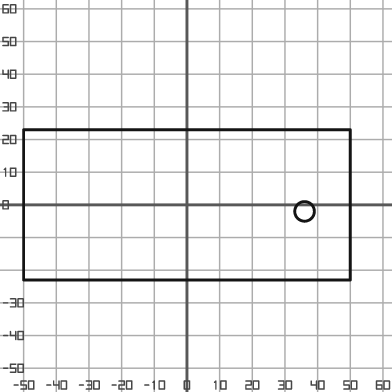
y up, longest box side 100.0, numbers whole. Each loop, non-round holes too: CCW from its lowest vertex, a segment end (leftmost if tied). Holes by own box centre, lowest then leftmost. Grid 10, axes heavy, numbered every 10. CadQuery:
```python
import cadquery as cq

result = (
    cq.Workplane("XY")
    .moveTo(-50.0, -23.0)
    .lineTo(50.0, -23.0)
    .lineTo(50.0, 23.0)
    .lineTo(-50.0, 23.0)
    .close()
    .moveTo(36.0, -2.0)
    .circle(3.0)
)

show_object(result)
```